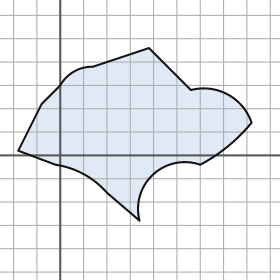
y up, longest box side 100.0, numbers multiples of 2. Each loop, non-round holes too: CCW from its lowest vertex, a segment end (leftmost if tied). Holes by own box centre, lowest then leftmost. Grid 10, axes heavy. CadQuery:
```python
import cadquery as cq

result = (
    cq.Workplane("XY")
    .moveTo(34.0, -28.0)
    .threePointArc((40.0, -8.0), (60.0, -4.0))
    .threePointArc((72.0, 4.0), (82.0, 14.0))
    .threePointArc((72.0, 26.0), (56.0, 28.0))
    .lineTo(38.0, 46.0)
    .lineTo(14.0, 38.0)
    .threePointArc((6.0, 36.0), (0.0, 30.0))
    .lineTo(-8.0, 22.0)
    .lineTo(-18.0, 2.0)
    .lineTo(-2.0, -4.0)
    .threePointArc((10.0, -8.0), (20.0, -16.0))
    .close()
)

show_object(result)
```